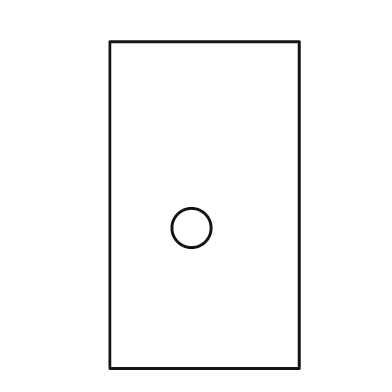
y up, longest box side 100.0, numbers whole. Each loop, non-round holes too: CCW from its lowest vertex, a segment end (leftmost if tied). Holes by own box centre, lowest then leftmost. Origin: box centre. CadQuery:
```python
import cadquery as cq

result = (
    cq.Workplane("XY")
    .moveTo(-29.0, -50.0)
    .lineTo(29.0, -50.0)
    .lineTo(29.0, 50.0)
    .lineTo(-29.0, 50.0)
    .close()
    .moveTo(-4.0, -7.0)
    .circle(6.0)
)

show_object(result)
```